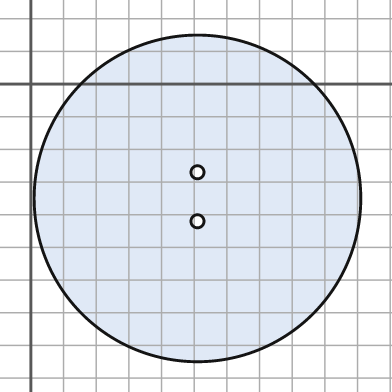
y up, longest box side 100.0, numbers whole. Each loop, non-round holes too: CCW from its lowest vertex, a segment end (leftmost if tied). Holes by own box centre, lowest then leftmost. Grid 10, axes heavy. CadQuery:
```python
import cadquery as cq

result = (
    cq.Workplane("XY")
    .moveTo(51.0, -35.0)
    .circle(50.0)
    .moveTo(51.0, -42.0)
    .circle(2.0)
    .moveTo(51.0, -27.0)
    .circle(2.0)
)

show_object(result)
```